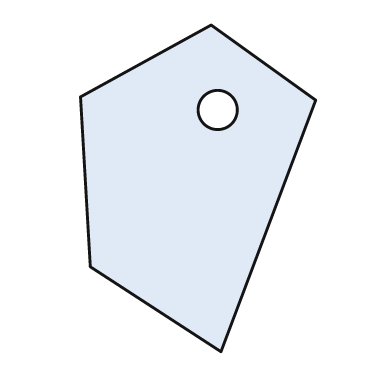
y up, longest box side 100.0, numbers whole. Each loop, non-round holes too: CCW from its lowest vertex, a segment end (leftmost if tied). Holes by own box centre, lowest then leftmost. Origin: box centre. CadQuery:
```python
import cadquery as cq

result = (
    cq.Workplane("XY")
    .moveTo(7.0, -50.0)
    .lineTo(36.0, 27.0)
    .lineTo(4.0, 50.0)
    .lineTo(-36.0, 28.0)
    .lineTo(-33.0, -24.0)
    .close()
    .moveTo(6.0, 24.0)
    .circle(6.0)
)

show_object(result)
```